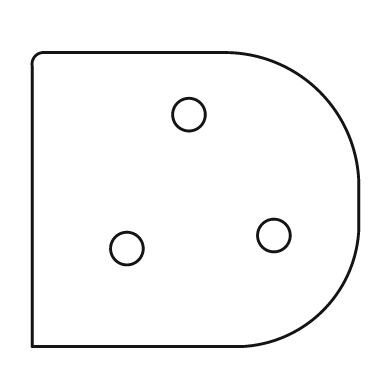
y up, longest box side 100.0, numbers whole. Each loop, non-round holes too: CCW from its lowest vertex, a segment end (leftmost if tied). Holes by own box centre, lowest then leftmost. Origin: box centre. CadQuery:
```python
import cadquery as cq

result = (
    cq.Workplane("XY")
    .moveTo(-50.0, -45.0)
    .lineTo(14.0, -45.0)
    .threePointArc((39.0, -34.0), (50.0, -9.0))
    .lineTo(50.0, 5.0)
    .threePointArc((38.0, 33.0), (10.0, 45.0))
    .lineTo(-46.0, 45.0)
    .threePointArc((-49.0, 44.0), (-50.0, 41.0))
    .close()
    .moveTo(-21.0, -15.0)
    .circle(5.0)
    .moveTo(24.0, -11.0)
    .circle(5.0)
    .moveTo(-2.0, 26.0)
    .circle(5.0)
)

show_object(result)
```